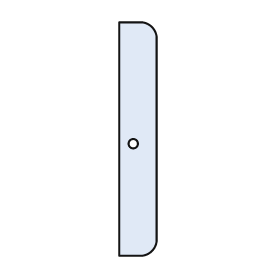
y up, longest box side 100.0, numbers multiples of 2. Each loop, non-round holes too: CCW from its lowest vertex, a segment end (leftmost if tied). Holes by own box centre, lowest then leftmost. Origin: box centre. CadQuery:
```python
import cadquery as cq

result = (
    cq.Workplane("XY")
    .moveTo(-8.0, -50.0)
    .lineTo(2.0, -50.0)
    .threePointArc((6.0, -48.0), (8.0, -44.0))
    .lineTo(8.0, 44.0)
    .threePointArc((6.0, 48.0), (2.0, 50.0))
    .lineTo(-8.0, 50.0)
    .close()
    .moveTo(-2.0, -2.0)
    .circle(2.0)
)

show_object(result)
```